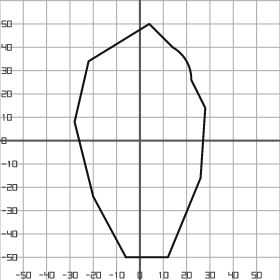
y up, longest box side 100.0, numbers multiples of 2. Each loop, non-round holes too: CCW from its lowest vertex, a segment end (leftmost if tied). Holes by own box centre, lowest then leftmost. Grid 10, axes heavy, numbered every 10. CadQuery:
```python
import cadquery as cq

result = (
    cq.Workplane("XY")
    .moveTo(-6.0, -50.0)
    .lineTo(12.0, -50.0)
    .lineTo(26.0, -16.0)
    .lineTo(28.0, 14.0)
    .lineTo(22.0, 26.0)
    .threePointArc((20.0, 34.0), (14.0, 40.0))
    .lineTo(4.0, 50.0)
    .lineTo(-22.0, 34.0)
    .lineTo(-28.0, 8.0)
    .lineTo(-20.0, -24.0)
    .close()
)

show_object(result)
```